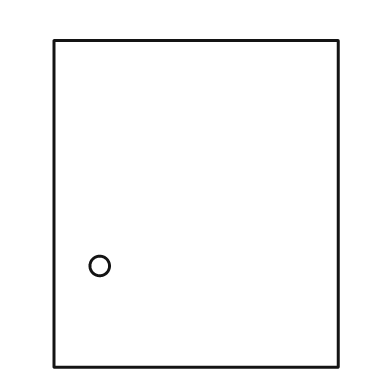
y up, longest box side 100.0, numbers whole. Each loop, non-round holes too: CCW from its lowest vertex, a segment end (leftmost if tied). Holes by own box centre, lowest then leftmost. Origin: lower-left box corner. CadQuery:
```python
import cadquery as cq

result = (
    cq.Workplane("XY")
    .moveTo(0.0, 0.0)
    .lineTo(87.0, 0.0)
    .lineTo(87.0, 100.0)
    .lineTo(0.0, 100.0)
    .close()
    .moveTo(14.0, 31.0)
    .circle(3.0)
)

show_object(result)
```